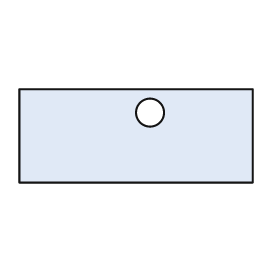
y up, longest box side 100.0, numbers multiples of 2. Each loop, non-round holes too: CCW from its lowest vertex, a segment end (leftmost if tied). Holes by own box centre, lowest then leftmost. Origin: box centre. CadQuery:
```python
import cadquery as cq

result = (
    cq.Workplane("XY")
    .moveTo(-50.0, -20.0)
    .lineTo(50.0, -20.0)
    .lineTo(50.0, 20.0)
    .lineTo(-50.0, 20.0)
    .close()
    .moveTo(6.0, 10.0)
    .circle(6.0)
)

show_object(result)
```